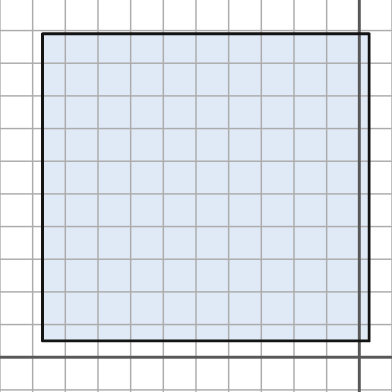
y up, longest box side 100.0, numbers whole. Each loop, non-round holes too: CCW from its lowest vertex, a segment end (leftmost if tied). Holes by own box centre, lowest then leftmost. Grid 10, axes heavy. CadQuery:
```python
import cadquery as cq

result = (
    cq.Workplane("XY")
    .moveTo(-97.0, 5.0)
    .lineTo(3.0, 5.0)
    .lineTo(3.0, 99.0)
    .lineTo(-97.0, 99.0)
    .close()
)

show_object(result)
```